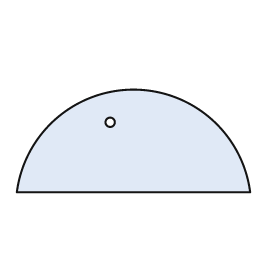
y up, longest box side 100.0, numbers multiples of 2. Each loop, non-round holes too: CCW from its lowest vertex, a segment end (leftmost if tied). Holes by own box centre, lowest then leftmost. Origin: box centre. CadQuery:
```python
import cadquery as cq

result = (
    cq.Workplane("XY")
    .moveTo(-50.0, -22.0)
    .lineTo(50.0, -22.0)
    .threePointArc((0.0, 22.0), (-50.0, -22.0))
    .close()
    .moveTo(-10.0, 8.0)
    .circle(2.0)
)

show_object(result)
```